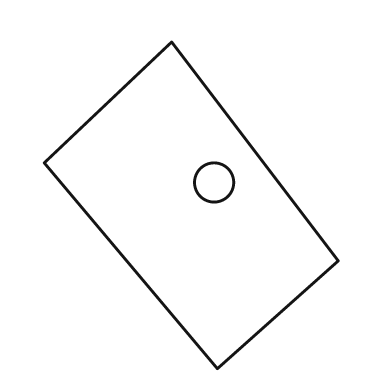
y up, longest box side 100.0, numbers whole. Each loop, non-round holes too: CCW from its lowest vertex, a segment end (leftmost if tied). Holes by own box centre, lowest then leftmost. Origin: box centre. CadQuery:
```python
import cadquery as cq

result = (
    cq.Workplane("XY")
    .moveTo(8.0, -50.0)
    .lineTo(45.0, -17.0)
    .lineTo(-6.0, 50.0)
    .lineTo(-45.0, 13.0)
    .close()
    .moveTo(7.0, 7.0)
    .circle(6.0)
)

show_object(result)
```